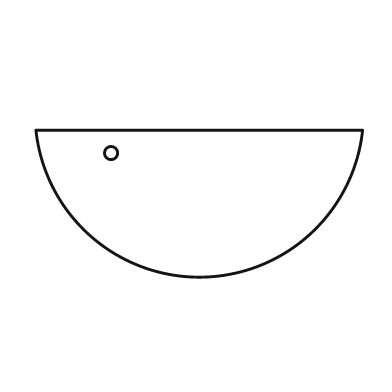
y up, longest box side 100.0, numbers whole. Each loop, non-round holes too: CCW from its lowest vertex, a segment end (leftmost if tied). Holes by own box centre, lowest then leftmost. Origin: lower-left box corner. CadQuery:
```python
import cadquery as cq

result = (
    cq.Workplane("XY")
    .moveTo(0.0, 45.0)
    .threePointArc((50.0, 0.0), (100.0, 45.0))
    .close()
    .moveTo(23.0, 38.0)
    .circle(2.0)
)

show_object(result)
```